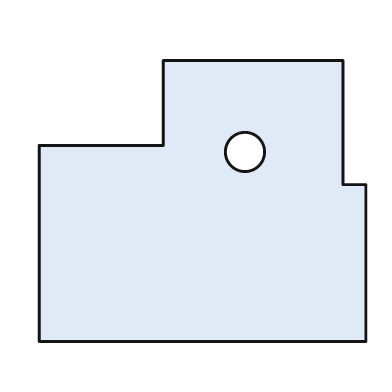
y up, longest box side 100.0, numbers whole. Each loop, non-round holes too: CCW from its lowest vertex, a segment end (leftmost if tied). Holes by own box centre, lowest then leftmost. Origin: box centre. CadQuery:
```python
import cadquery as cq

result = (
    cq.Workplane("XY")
    .moveTo(-50.0, -43.0)
    .lineTo(50.0, -43.0)
    .lineTo(50.0, 5.0)
    .lineTo(43.0, 5.0)
    .lineTo(43.0, 43.0)
    .lineTo(-12.0, 43.0)
    .lineTo(-12.0, 17.0)
    .lineTo(-50.0, 17.0)
    .close()
    .moveTo(13.0, 15.0)
    .circle(6.0)
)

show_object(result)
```